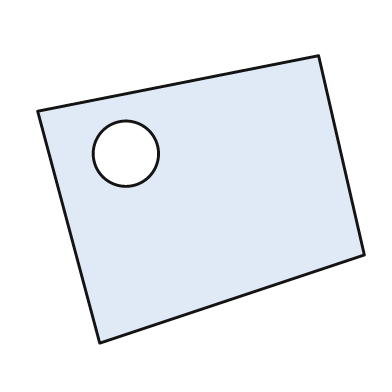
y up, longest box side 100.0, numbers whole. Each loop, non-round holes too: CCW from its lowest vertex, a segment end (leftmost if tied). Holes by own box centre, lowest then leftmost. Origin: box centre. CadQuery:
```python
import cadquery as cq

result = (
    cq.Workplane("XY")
    .moveTo(-31.0, -44.0)
    .lineTo(50.0, -17.0)
    .lineTo(36.0, 44.0)
    .lineTo(-50.0, 27.0)
    .close()
    .moveTo(-23.0, 14.0)
    .circle(10.0)
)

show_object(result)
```